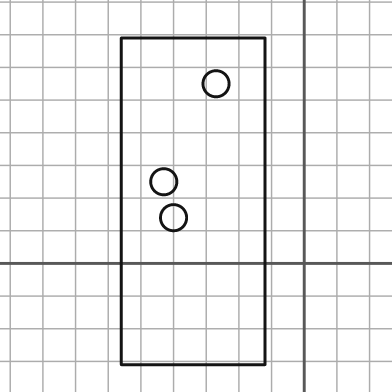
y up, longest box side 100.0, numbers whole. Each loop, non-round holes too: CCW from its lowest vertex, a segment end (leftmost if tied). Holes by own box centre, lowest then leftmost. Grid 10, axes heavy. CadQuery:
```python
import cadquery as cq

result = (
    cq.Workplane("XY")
    .moveTo(-56.0, -31.0)
    .lineTo(-12.0, -31.0)
    .lineTo(-12.0, 69.0)
    .lineTo(-56.0, 69.0)
    .close()
    .moveTo(-40.0, 14.0)
    .circle(4.0)
    .moveTo(-43.0, 25.0)
    .circle(4.0)
    .moveTo(-27.0, 55.0)
    .circle(4.0)
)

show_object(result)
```